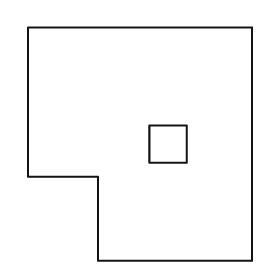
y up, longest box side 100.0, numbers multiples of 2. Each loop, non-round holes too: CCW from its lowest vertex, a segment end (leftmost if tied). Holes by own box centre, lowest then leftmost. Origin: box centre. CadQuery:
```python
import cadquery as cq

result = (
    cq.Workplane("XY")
    .moveTo(-18.0, -50.0)
    .lineTo(48.0, -50.0)
    .lineTo(48.0, 50.0)
    .lineTo(-48.0, 50.0)
    .lineTo(-48.0, -14.0)
    .lineTo(-18.0, -14.0)
    .close()
    .moveTo(4.0, -8.0)
    .lineTo(20.0, -8.0)
    .lineTo(20.0, 8.0)
    .lineTo(4.0, 8.0)
    .close()
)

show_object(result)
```